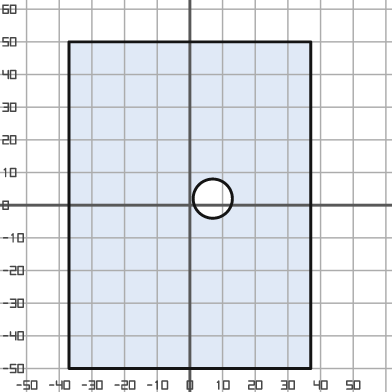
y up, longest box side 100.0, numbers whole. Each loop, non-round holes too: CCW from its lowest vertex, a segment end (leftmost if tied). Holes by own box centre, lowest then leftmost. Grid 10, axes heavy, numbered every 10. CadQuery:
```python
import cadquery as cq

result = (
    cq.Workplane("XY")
    .moveTo(-37.0, -50.0)
    .lineTo(37.0, -50.0)
    .lineTo(37.0, 50.0)
    .lineTo(-37.0, 50.0)
    .close()
    .moveTo(7.0, 2.0)
    .circle(6.0)
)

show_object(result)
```